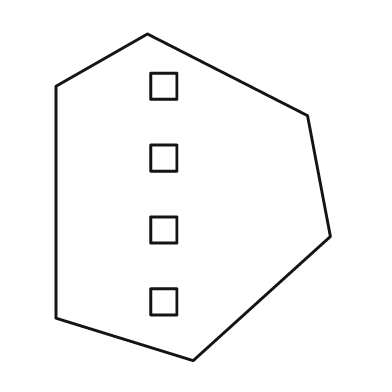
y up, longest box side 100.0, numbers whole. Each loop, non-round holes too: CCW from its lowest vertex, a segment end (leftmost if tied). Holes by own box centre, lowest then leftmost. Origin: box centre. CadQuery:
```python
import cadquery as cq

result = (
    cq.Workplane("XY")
    .moveTo(0.0, -50.0)
    .lineTo(42.0, -12.0)
    .lineTo(35.0, 25.0)
    .lineTo(-14.0, 50.0)
    .lineTo(-42.0, 34.0)
    .lineTo(-42.0, -37.0)
    .close()
    .moveTo(-13.0, -36.0)
    .lineTo(-5.0, -36.0)
    .lineTo(-5.0, -28.0)
    .lineTo(-13.0, -28.0)
    .close()
    .moveTo(-13.0, -14.0)
    .lineTo(-5.0, -14.0)
    .lineTo(-5.0, -6.0)
    .lineTo(-13.0, -6.0)
    .close()
    .moveTo(-13.0, 8.0)
    .lineTo(-5.0, 8.0)
    .lineTo(-5.0, 16.0)
    .lineTo(-13.0, 16.0)
    .close()
    .moveTo(-13.0, 30.0)
    .lineTo(-5.0, 30.0)
    .lineTo(-5.0, 38.0)
    .lineTo(-13.0, 38.0)
    .close()
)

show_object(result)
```